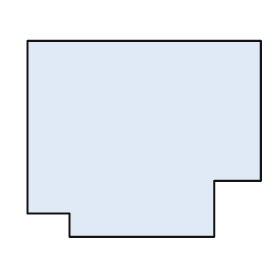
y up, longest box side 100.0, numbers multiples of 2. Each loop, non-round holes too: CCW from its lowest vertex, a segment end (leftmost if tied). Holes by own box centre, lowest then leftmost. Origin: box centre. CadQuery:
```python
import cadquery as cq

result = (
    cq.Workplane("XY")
    .moveTo(-32.0, -42.0)
    .lineTo(30.0, -42.0)
    .lineTo(30.0, -18.0)
    .lineTo(50.0, -18.0)
    .lineTo(50.0, 42.0)
    .lineTo(-50.0, 42.0)
    .lineTo(-50.0, -32.0)
    .lineTo(-32.0, -32.0)
    .close()
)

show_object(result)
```